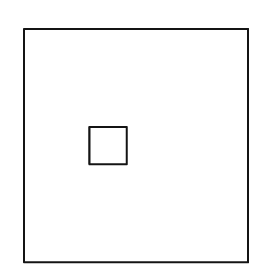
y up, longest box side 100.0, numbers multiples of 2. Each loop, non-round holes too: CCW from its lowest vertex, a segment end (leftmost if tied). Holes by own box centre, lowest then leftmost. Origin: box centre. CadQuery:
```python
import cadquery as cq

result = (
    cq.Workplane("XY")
    .moveTo(-48.0, -50.0)
    .lineTo(48.0, -50.0)
    .lineTo(48.0, 50.0)
    .lineTo(-48.0, 50.0)
    .close()
    .moveTo(-20.0, -8.0)
    .lineTo(-4.0, -8.0)
    .lineTo(-4.0, 8.0)
    .lineTo(-20.0, 8.0)
    .close()
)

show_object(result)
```